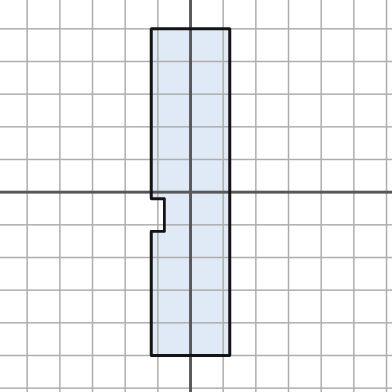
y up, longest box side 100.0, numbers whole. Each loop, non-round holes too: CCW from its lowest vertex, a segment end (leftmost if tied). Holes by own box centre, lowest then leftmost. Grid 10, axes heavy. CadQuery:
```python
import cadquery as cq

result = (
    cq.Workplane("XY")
    .moveTo(-12.0, -50.0)
    .lineTo(12.0, -50.0)
    .lineTo(12.0, 50.0)
    .lineTo(-12.0, 50.0)
    .lineTo(-12.0, -2.0)
    .lineTo(-8.0, -2.0)
    .lineTo(-8.0, -12.0)
    .lineTo(-12.0, -12.0)
    .close()
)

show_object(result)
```